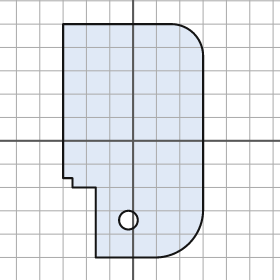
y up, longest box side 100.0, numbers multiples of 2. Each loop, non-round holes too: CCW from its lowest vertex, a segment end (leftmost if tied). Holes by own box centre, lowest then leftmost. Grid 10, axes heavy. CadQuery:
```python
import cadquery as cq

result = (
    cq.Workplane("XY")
    .moveTo(-16.0, -50.0)
    .lineTo(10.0, -50.0)
    .threePointArc((24.0, -44.0), (30.0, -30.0))
    .lineTo(30.0, 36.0)
    .threePointArc((26.0, 46.0), (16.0, 50.0))
    .lineTo(-30.0, 50.0)
    .lineTo(-30.0, -16.0)
    .lineTo(-26.0, -16.0)
    .lineTo(-26.0, -20.0)
    .lineTo(-16.0, -20.0)
    .close()
    .moveTo(-2.0, -34.0)
    .circle(4.0)
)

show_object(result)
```